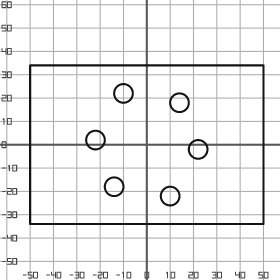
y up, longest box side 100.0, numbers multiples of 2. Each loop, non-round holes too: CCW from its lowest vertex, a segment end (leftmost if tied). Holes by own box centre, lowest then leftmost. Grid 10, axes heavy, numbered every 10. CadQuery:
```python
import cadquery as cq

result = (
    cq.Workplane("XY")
    .moveTo(-50.0, -34.0)
    .lineTo(50.0, -34.0)
    .lineTo(50.0, 34.0)
    .lineTo(-50.0, 34.0)
    .close()
    .moveTo(10.0, -22.0)
    .circle(4.0)
    .moveTo(-14.0, -18.0)
    .circle(4.0)
    .moveTo(22.0, -2.0)
    .circle(4.0)
    .moveTo(-22.0, 2.0)
    .circle(4.0)
    .moveTo(14.0, 18.0)
    .circle(4.0)
    .moveTo(-10.0, 22.0)
    .circle(4.0)
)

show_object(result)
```